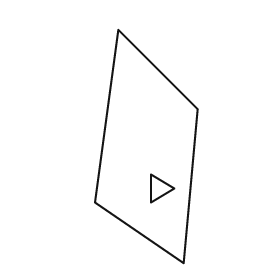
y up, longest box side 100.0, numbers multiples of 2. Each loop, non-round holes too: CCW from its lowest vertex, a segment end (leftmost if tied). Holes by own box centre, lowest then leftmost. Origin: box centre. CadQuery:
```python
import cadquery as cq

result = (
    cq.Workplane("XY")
    .moveTo(16.0, -50.0)
    .lineTo(22.0, 16.0)
    .lineTo(-12.0, 50.0)
    .lineTo(-22.0, -24.0)
    .close()
    .moveTo(2.0, -24.0)
    .lineTo(12.0, -18.0)
    .lineTo(2.0, -12.0)
    .close()
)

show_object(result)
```